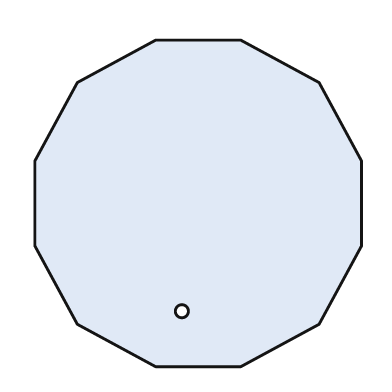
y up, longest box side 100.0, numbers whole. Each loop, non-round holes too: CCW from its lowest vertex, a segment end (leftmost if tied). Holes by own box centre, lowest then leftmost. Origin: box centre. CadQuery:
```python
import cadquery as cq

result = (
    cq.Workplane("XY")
    .moveTo(-13.0, -50.0)
    .lineTo(13.0, -50.0)
    .lineTo(37.0, -37.0)
    .lineTo(50.0, -13.0)
    .lineTo(50.0, 13.0)
    .lineTo(37.0, 37.0)
    .lineTo(13.0, 50.0)
    .lineTo(-13.0, 50.0)
    .lineTo(-37.0, 37.0)
    .lineTo(-50.0, 13.0)
    .lineTo(-50.0, -13.0)
    .lineTo(-37.0, -37.0)
    .close()
    .moveTo(-5.0, -33.0)
    .circle(2.0)
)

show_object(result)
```